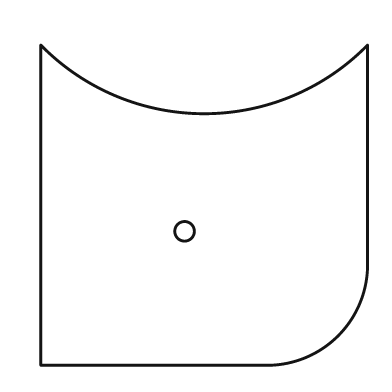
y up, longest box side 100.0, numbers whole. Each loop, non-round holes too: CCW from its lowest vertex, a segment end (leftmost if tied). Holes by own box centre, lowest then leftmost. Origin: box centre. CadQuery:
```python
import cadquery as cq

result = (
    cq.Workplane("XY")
    .moveTo(-50.0, -49.0)
    .lineTo(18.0, -49.0)
    .threePointArc((41.0, -40.0), (50.0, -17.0))
    .lineTo(50.0, 49.0)
    .threePointArc((0.0, 28.0), (-50.0, 49.0))
    .close()
    .moveTo(-6.0, -8.0)
    .circle(3.0)
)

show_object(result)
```